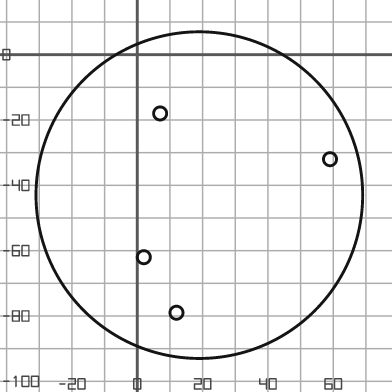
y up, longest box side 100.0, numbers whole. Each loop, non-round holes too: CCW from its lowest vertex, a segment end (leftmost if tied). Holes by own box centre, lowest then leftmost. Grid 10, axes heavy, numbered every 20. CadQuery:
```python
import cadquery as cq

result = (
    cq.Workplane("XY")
    .moveTo(19.0, -43.0)
    .circle(50.0)
    .moveTo(12.0, -79.0)
    .circle(2.0)
    .moveTo(2.0, -62.0)
    .circle(2.0)
    .moveTo(59.0, -32.0)
    .circle(2.0)
    .moveTo(7.0, -18.0)
    .circle(2.0)
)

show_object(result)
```